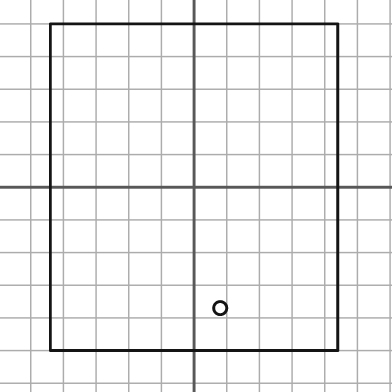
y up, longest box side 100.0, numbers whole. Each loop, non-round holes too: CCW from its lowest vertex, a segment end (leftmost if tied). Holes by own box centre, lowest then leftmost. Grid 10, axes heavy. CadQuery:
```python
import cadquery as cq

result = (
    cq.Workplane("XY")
    .moveTo(-44.0, -50.0)
    .lineTo(44.0, -50.0)
    .lineTo(44.0, 50.0)
    .lineTo(-44.0, 50.0)
    .close()
    .moveTo(8.0, -37.0)
    .circle(2.0)
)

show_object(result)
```